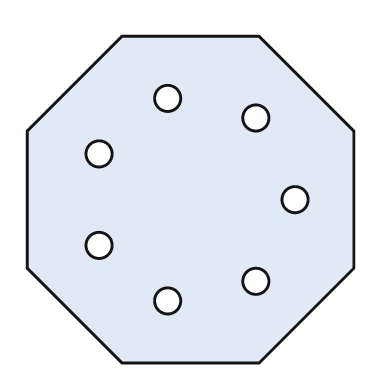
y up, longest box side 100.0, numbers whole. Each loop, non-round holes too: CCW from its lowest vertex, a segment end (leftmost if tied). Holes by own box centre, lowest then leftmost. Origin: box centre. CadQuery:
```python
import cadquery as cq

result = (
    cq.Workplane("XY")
    .moveTo(-21.0, -50.0)
    .lineTo(21.0, -50.0)
    .lineTo(50.0, -21.0)
    .lineTo(50.0, 21.0)
    .lineTo(21.0, 50.0)
    .lineTo(-21.0, 50.0)
    .lineTo(-50.0, 21.0)
    .lineTo(-50.0, -21.0)
    .close()
    .moveTo(-7.0, -31.0)
    .circle(4.0)
    .moveTo(20.0, -25.0)
    .circle(4.0)
    .moveTo(-28.0, -14.0)
    .circle(4.0)
    .moveTo(32.0, 0.0)
    .circle(4.0)
    .moveTo(-28.0, 14.0)
    .circle(4.0)
    .moveTo(20.0, 25.0)
    .circle(4.0)
    .moveTo(-7.0, 31.0)
    .circle(4.0)
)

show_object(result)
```